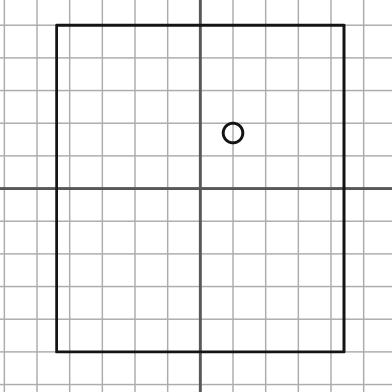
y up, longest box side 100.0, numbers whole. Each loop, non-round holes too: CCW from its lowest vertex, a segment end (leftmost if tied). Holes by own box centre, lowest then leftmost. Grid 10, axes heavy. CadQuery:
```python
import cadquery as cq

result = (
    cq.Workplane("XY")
    .moveTo(-44.0, -50.0)
    .lineTo(44.0, -50.0)
    .lineTo(44.0, 50.0)
    .lineTo(-44.0, 50.0)
    .close()
    .moveTo(10.0, 17.0)
    .circle(3.0)
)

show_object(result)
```